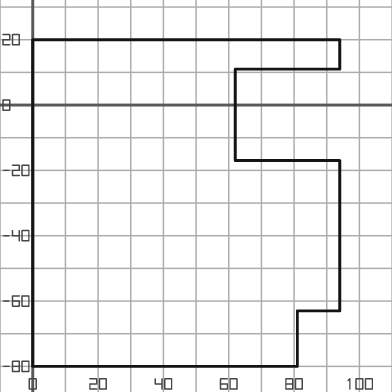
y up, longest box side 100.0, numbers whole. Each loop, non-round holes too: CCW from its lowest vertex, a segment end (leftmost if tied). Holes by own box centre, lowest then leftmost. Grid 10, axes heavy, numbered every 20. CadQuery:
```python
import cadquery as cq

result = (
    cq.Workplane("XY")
    .moveTo(0.0, -80.0)
    .lineTo(81.0, -80.0)
    .lineTo(81.0, -63.0)
    .lineTo(94.0, -63.0)
    .lineTo(94.0, -17.0)
    .lineTo(62.0, -17.0)
    .lineTo(62.0, 11.0)
    .lineTo(94.0, 11.0)
    .lineTo(94.0, 20.0)
    .lineTo(0.0, 20.0)
    .close()
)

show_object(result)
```